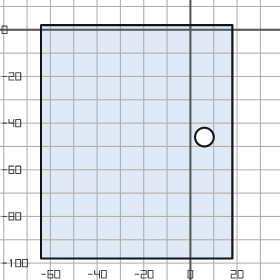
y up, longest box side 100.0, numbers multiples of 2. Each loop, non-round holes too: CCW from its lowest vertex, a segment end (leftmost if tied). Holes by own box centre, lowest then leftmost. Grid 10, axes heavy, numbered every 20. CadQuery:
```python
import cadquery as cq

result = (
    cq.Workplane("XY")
    .moveTo(-64.0, -98.0)
    .lineTo(18.0, -98.0)
    .lineTo(18.0, 2.0)
    .lineTo(-64.0, 2.0)
    .close()
    .moveTo(6.0, -46.0)
    .circle(4.0)
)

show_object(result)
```